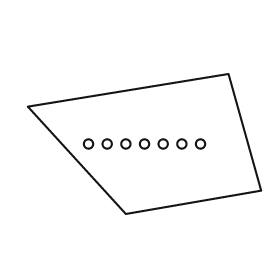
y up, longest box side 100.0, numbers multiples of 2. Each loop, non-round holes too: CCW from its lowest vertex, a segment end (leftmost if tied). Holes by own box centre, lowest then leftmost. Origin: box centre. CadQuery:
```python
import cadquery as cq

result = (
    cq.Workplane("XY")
    .moveTo(-8.0, -30.0)
    .lineTo(50.0, -20.0)
    .lineTo(36.0, 30.0)
    .lineTo(-50.0, 16.0)
    .close()
    .moveTo(-24.0, 0.0)
    .circle(2.0)
    .moveTo(-16.0, 0.0)
    .circle(2.0)
    .moveTo(-8.0, 0.0)
    .circle(2.0)
    .moveTo(0.0, 0.0)
    .circle(2.0)
    .moveTo(8.0, 0.0)
    .circle(2.0)
    .moveTo(16.0, 0.0)
    .circle(2.0)
    .moveTo(24.0, 0.0)
    .circle(2.0)
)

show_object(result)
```